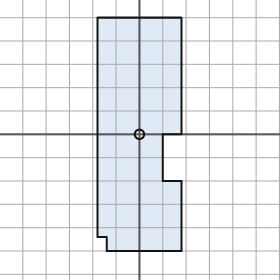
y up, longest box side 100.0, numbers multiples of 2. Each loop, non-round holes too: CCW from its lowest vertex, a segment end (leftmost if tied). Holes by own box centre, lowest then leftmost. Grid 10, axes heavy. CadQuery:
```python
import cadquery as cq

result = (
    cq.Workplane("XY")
    .moveTo(-14.0, -50.0)
    .lineTo(18.0, -50.0)
    .lineTo(18.0, -20.0)
    .lineTo(10.0, -20.0)
    .lineTo(10.0, 0.0)
    .lineTo(18.0, 0.0)
    .lineTo(18.0, 50.0)
    .lineTo(-18.0, 50.0)
    .lineTo(-18.0, -44.0)
    .lineTo(-14.0, -44.0)
    .close()
    .moveTo(0.0, 0.0)
    .circle(2.0)
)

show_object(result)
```